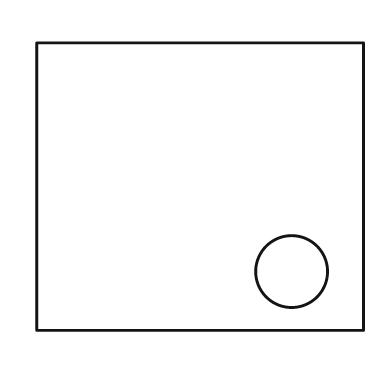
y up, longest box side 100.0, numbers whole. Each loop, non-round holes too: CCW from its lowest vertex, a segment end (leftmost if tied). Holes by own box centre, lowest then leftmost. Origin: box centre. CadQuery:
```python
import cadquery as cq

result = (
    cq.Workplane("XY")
    .moveTo(-50.0, -44.0)
    .lineTo(50.0, -44.0)
    .lineTo(50.0, 44.0)
    .lineTo(-50.0, 44.0)
    .close()
    .moveTo(28.0, -26.0)
    .circle(11.0)
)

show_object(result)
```